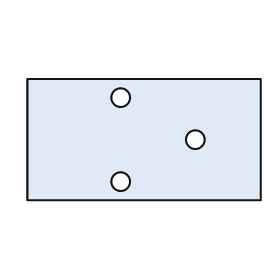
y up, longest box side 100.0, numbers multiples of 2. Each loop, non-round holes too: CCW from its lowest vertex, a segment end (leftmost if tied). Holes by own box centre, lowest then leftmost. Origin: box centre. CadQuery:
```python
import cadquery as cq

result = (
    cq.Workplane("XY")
    .moveTo(-50.0, -26.0)
    .lineTo(50.0, -26.0)
    .lineTo(50.0, 26.0)
    .lineTo(-50.0, 26.0)
    .close()
    .moveTo(-10.0, -18.0)
    .circle(4.0)
    .moveTo(22.0, 0.0)
    .circle(4.0)
    .moveTo(-10.0, 18.0)
    .circle(4.0)
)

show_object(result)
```